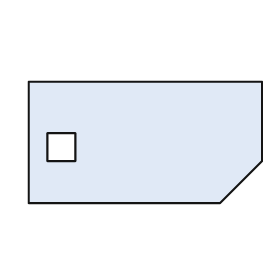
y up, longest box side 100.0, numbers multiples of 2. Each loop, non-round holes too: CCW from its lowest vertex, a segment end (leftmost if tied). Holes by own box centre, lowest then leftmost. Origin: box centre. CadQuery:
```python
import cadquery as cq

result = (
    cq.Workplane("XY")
    .moveTo(-50.0, -26.0)
    .lineTo(32.0, -26.0)
    .lineTo(50.0, -8.0)
    .lineTo(50.0, 26.0)
    .lineTo(-50.0, 26.0)
    .close()
    .moveTo(-42.0, -8.0)
    .lineTo(-30.0, -8.0)
    .lineTo(-30.0, 4.0)
    .lineTo(-42.0, 4.0)
    .close()
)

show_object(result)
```